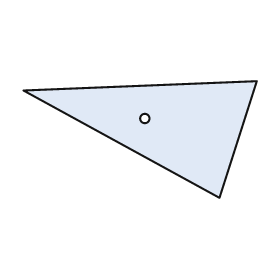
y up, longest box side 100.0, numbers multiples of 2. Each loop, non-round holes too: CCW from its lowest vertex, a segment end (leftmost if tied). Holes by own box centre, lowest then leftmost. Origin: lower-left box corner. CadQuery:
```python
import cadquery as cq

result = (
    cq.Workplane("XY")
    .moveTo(84.0, 0.0)
    .lineTo(100.0, 50.0)
    .lineTo(0.0, 46.0)
    .close()
    .moveTo(52.0, 34.0)
    .circle(2.0)
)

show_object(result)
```